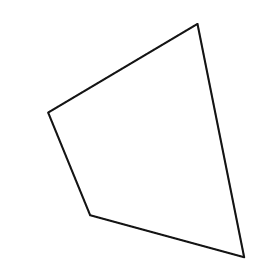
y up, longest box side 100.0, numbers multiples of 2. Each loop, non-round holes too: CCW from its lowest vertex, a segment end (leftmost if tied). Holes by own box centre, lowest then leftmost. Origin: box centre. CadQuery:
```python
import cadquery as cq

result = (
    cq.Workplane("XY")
    .moveTo(42.0, -50.0)
    .lineTo(22.0, 50.0)
    .lineTo(-42.0, 12.0)
    .lineTo(-24.0, -32.0)
    .close()
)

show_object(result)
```